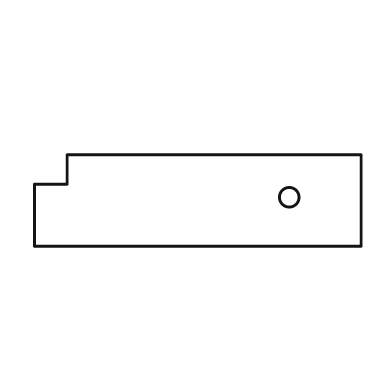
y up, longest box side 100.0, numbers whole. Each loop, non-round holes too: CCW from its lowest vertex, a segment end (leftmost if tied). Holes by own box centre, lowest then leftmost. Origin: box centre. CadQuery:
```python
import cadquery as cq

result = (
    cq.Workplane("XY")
    .moveTo(-50.0, -14.0)
    .lineTo(50.0, -14.0)
    .lineTo(50.0, 14.0)
    .lineTo(-40.0, 14.0)
    .lineTo(-40.0, 5.0)
    .lineTo(-50.0, 5.0)
    .close()
    .moveTo(28.0, 1.0)
    .circle(3.0)
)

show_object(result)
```